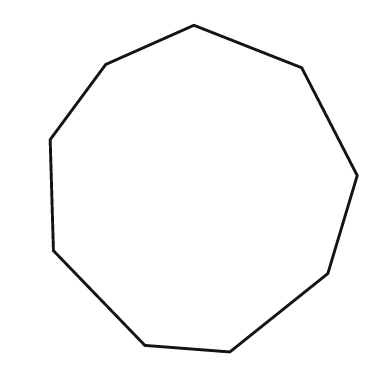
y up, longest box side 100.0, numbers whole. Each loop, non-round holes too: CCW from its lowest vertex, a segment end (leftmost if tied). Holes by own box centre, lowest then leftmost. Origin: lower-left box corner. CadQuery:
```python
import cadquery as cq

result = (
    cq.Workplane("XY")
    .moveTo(55.0, 0.0)
    .lineTo(85.0, 24.0)
    .lineTo(94.0, 54.0)
    .lineTo(77.0, 87.0)
    .lineTo(44.0, 100.0)
    .lineTo(17.0, 88.0)
    .lineTo(0.0, 65.0)
    .lineTo(1.0, 31.0)
    .lineTo(29.0, 2.0)
    .close()
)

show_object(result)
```